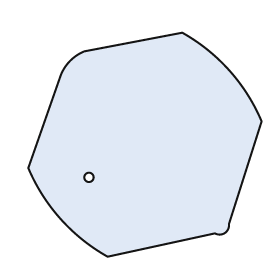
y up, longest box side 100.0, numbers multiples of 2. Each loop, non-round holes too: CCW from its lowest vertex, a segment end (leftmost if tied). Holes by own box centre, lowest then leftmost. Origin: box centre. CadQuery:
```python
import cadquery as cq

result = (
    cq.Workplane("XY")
    .moveTo(-16.0, -48.0)
    .lineTo(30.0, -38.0)
    .threePointArc((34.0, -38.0), (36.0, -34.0))
    .lineTo(50.0, 10.0)
    .threePointArc((36.0, 32.0), (16.0, 48.0))
    .lineTo(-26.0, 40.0)
    .threePointArc((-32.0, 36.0), (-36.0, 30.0))
    .lineTo(-50.0, -10.0)
    .threePointArc((-36.0, -32.0), (-16.0, -48.0))
    .close()
    .moveTo(-24.0, -14.0)
    .circle(2.0)
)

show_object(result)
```